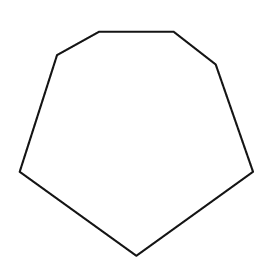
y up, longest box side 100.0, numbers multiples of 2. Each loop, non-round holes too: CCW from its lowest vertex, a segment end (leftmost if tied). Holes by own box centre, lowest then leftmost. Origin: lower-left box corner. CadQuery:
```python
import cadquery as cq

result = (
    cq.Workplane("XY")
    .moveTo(50.0, 0.0)
    .lineTo(100.0, 36.0)
    .lineTo(84.0, 82.0)
    .lineTo(66.0, 96.0)
    .lineTo(34.0, 96.0)
    .lineTo(16.0, 86.0)
    .lineTo(0.0, 36.0)
    .close()
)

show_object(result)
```